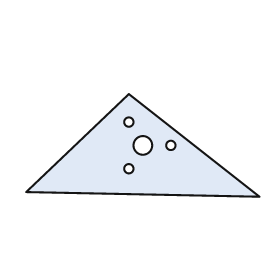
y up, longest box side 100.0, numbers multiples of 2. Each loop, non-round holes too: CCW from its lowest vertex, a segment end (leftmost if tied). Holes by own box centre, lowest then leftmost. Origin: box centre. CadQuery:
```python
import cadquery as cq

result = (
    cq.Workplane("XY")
    .moveTo(50.0, -22.0)
    .lineTo(-6.0, 22.0)
    .lineTo(-50.0, -20.0)
    .close()
    .moveTo(-6.0, -10.0)
    .circle(2.0)
    .moveTo(0.0, 0.0)
    .circle(4.0)
    .moveTo(12.0, 0.0)
    .circle(2.0)
    .moveTo(-6.0, 10.0)
    .circle(2.0)
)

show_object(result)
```